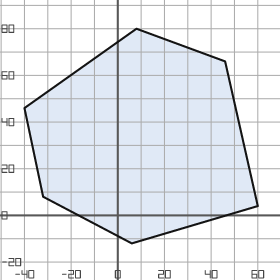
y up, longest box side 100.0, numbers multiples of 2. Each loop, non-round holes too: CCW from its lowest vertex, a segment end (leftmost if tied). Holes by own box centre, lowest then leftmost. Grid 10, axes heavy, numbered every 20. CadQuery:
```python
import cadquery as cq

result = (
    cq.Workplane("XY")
    .moveTo(6.0, -12.0)
    .lineTo(60.0, 4.0)
    .lineTo(46.0, 66.0)
    .lineTo(8.0, 80.0)
    .lineTo(-40.0, 46.0)
    .lineTo(-32.0, 8.0)
    .close()
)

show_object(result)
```